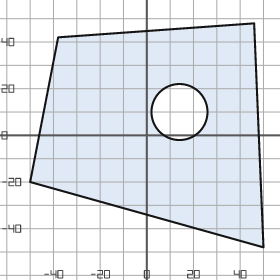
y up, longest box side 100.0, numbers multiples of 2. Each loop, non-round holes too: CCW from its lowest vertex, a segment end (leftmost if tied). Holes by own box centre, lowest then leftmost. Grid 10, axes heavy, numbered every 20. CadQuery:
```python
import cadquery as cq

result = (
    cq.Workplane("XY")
    .moveTo(50.0, -48.0)
    .lineTo(46.0, 48.0)
    .lineTo(-38.0, 42.0)
    .lineTo(-50.0, -20.0)
    .close()
    .moveTo(14.0, 10.0)
    .circle(12.0)
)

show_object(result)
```